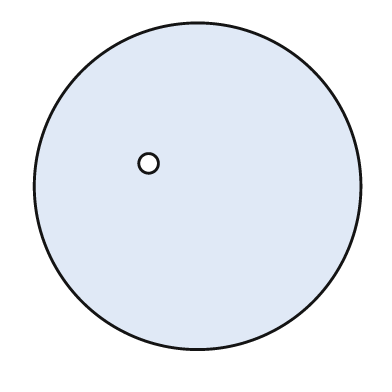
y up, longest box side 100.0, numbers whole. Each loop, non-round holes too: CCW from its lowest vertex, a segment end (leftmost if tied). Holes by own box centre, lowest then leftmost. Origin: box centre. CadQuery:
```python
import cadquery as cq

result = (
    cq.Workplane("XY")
    .moveTo(0.0, 0.0)
    .circle(50.0)
    .moveTo(-15.0, 7.0)
    .circle(3.0)
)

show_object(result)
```